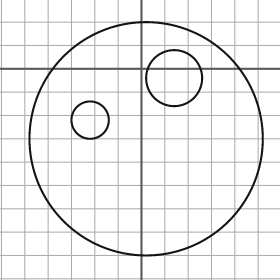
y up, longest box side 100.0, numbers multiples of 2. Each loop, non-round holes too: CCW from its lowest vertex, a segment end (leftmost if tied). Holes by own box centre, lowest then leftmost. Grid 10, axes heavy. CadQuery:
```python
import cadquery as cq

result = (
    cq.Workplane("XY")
    .moveTo(2.0, -30.0)
    .circle(50.0)
    .moveTo(-22.0, -22.0)
    .circle(8.0)
    .moveTo(14.0, -4.0)
    .circle(12.0)
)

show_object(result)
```